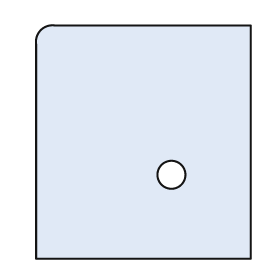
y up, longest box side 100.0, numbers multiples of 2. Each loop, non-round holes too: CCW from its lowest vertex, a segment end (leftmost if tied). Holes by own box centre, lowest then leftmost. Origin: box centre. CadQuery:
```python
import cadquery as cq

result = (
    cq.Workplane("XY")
    .moveTo(-46.0, -50.0)
    .lineTo(46.0, -50.0)
    .lineTo(46.0, 50.0)
    .lineTo(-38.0, 50.0)
    .threePointArc((-44.0, 48.0), (-46.0, 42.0))
    .close()
    .moveTo(12.0, -14.0)
    .circle(6.0)
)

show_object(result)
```